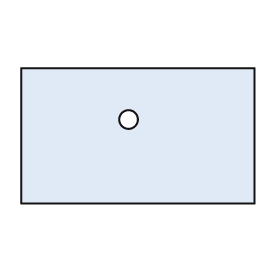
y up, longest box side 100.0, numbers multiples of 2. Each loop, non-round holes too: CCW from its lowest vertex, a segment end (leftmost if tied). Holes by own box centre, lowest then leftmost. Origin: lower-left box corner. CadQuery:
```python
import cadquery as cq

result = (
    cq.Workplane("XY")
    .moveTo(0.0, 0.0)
    .lineTo(100.0, 0.0)
    .lineTo(100.0, 58.0)
    .lineTo(0.0, 58.0)
    .close()
    .moveTo(46.0, 36.0)
    .circle(4.0)
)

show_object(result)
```